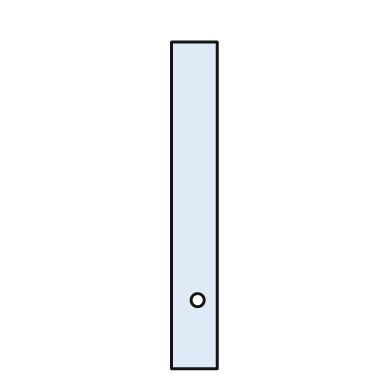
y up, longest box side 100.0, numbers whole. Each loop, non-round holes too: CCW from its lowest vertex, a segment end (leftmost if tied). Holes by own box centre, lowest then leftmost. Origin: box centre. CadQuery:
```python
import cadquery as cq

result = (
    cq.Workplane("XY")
    .moveTo(-7.0, -50.0)
    .lineTo(7.0, -50.0)
    .lineTo(7.0, 50.0)
    .lineTo(-7.0, 50.0)
    .close()
    .moveTo(1.0, -29.0)
    .circle(2.0)
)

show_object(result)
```